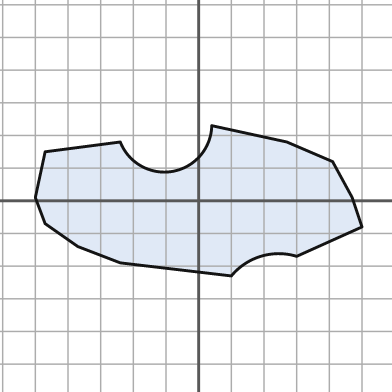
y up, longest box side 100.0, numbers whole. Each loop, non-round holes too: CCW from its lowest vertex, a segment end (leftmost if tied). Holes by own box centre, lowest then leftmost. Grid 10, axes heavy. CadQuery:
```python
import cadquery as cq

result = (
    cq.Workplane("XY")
    .moveTo(10.0, -23.0)
    .threePointArc((19.0, -17.0), (30.0, -17.0))
    .lineTo(50.0, -8.0)
    .lineTo(47.0, 1.0)
    .lineTo(41.0, 12.0)
    .lineTo(27.0, 18.0)
    .lineTo(4.0, 23.0)
    .threePointArc((-8.0, 9.0), (-24.0, 18.0))
    .lineTo(-47.0, 15.0)
    .lineTo(-50.0, 1.0)
    .lineTo(-47.0, -7.0)
    .lineTo(-37.0, -14.0)
    .lineTo(-24.0, -19.0)
    .close()
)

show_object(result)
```